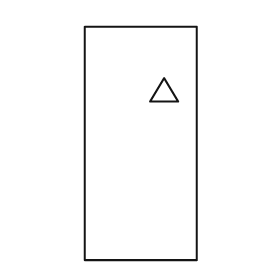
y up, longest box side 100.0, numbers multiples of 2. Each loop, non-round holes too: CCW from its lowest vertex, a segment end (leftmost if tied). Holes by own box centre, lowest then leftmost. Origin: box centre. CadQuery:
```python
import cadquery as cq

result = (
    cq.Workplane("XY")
    .moveTo(-24.0, -50.0)
    .lineTo(24.0, -50.0)
    .lineTo(24.0, 50.0)
    .lineTo(-24.0, 50.0)
    .close()
    .moveTo(4.0, 18.0)
    .lineTo(16.0, 18.0)
    .lineTo(10.0, 28.0)
    .close()
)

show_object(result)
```